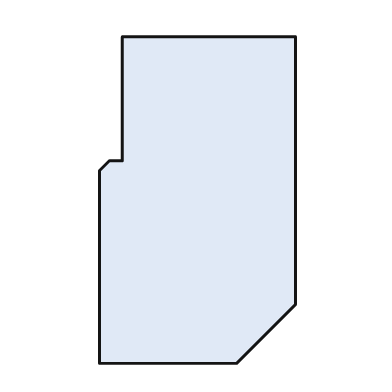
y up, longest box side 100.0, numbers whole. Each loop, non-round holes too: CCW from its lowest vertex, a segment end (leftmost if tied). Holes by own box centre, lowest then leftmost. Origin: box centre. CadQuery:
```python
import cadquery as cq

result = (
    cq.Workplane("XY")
    .moveTo(-30.0, -50.0)
    .lineTo(12.0, -50.0)
    .lineTo(30.0, -32.0)
    .lineTo(30.0, 50.0)
    .lineTo(-23.0, 50.0)
    .lineTo(-23.0, 12.0)
    .lineTo(-27.0, 12.0)
    .lineTo(-30.0, 9.0)
    .close()
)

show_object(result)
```